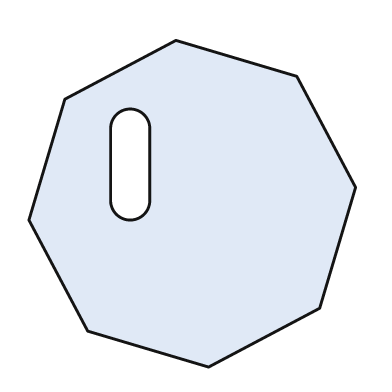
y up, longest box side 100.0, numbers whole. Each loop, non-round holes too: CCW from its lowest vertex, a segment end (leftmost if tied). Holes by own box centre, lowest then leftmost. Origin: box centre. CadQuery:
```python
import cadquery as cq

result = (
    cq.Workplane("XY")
    .moveTo(5.0, -50.0)
    .lineTo(39.0, -32.0)
    .lineTo(50.0, 5.0)
    .lineTo(32.0, 39.0)
    .lineTo(-5.0, 50.0)
    .lineTo(-39.0, 32.0)
    .lineTo(-50.0, -5.0)
    .lineTo(-32.0, -39.0)
    .close()
    .moveTo(-25.0, 1.0)
    .threePointArc((-19.0, -5.0), (-13.0, 1.0))
    .lineTo(-13.0, 23.0)
    .threePointArc((-19.0, 29.0), (-25.0, 23.0))
    .close()
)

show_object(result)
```